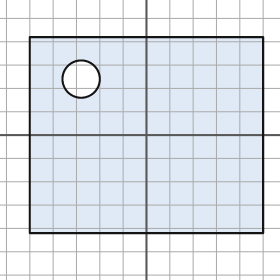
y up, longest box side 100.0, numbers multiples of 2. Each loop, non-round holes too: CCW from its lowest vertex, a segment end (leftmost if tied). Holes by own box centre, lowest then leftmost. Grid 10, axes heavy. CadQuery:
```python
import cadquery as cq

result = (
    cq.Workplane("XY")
    .moveTo(-50.0, -42.0)
    .lineTo(50.0, -42.0)
    .lineTo(50.0, 42.0)
    .lineTo(-50.0, 42.0)
    .close()
    .moveTo(-28.0, 24.0)
    .circle(8.0)
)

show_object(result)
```